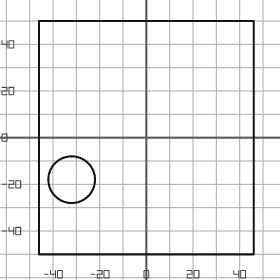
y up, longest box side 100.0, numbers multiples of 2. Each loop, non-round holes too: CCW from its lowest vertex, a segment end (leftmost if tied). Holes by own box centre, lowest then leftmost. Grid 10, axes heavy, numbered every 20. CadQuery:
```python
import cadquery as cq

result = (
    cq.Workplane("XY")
    .moveTo(-46.0, -50.0)
    .lineTo(46.0, -50.0)
    .lineTo(46.0, 50.0)
    .lineTo(-46.0, 50.0)
    .close()
    .moveTo(-32.0, -18.0)
    .circle(10.0)
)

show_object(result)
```